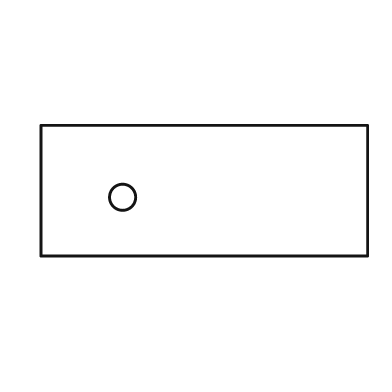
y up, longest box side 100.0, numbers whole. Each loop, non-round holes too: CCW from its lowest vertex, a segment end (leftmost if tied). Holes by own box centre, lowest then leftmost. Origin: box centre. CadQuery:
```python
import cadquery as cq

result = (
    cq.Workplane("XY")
    .moveTo(-50.0, -20.0)
    .lineTo(50.0, -20.0)
    .lineTo(50.0, 20.0)
    .lineTo(-50.0, 20.0)
    .close()
    .moveTo(-25.0, -2.0)
    .circle(4.0)
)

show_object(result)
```